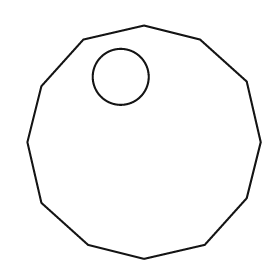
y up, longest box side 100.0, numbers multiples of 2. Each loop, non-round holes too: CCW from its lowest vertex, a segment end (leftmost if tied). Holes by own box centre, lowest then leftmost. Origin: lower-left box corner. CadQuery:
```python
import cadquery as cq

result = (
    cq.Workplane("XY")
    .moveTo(50.0, 0.0)
    .lineTo(76.0, 6.0)
    .lineTo(94.0, 26.0)
    .lineTo(100.0, 50.0)
    .lineTo(94.0, 76.0)
    .lineTo(74.0, 94.0)
    .lineTo(50.0, 100.0)
    .lineTo(24.0, 94.0)
    .lineTo(6.0, 74.0)
    .lineTo(0.0, 50.0)
    .lineTo(6.0, 24.0)
    .lineTo(26.0, 6.0)
    .close()
    .moveTo(40.0, 78.0)
    .circle(12.0)
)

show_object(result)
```